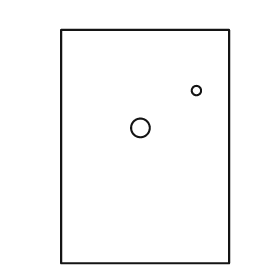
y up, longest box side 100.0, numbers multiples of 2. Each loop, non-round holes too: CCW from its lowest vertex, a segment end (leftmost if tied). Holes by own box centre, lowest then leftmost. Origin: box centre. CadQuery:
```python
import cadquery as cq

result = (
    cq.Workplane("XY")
    .moveTo(-36.0, -50.0)
    .lineTo(36.0, -50.0)
    .lineTo(36.0, 50.0)
    .lineTo(-36.0, 50.0)
    .close()
    .moveTo(-2.0, 8.0)
    .circle(4.0)
    .moveTo(22.0, 24.0)
    .circle(2.0)
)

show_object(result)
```